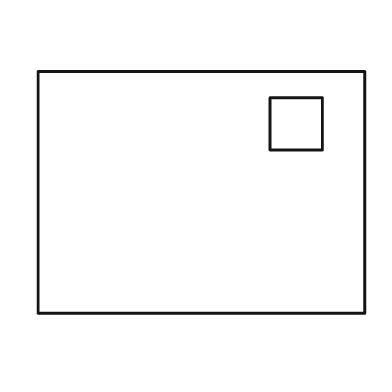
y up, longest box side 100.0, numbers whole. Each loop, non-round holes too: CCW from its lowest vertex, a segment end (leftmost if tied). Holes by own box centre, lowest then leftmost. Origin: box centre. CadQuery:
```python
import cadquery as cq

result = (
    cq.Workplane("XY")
    .moveTo(-50.0, -37.0)
    .lineTo(50.0, -37.0)
    .lineTo(50.0, 37.0)
    .lineTo(-50.0, 37.0)
    .close()
    .moveTo(21.0, 13.0)
    .lineTo(37.0, 13.0)
    .lineTo(37.0, 29.0)
    .lineTo(21.0, 29.0)
    .close()
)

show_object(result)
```